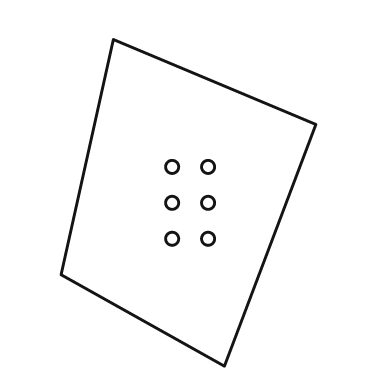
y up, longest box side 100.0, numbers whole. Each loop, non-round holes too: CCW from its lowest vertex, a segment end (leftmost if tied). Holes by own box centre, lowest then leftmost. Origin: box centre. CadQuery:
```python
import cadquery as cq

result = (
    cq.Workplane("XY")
    .moveTo(11.0, -50.0)
    .lineTo(39.0, 24.0)
    .lineTo(-23.0, 50.0)
    .lineTo(-39.0, -22.0)
    .close()
    .moveTo(-5.0, -11.0)
    .circle(2.0)
    .moveTo(6.0, -11.0)
    .circle(2.0)
    .moveTo(-5.0, 0.0)
    .circle(2.0)
    .moveTo(6.0, 0.0)
    .circle(2.0)
    .moveTo(-5.0, 11.0)
    .circle(2.0)
    .moveTo(6.0, 11.0)
    .circle(2.0)
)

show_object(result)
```